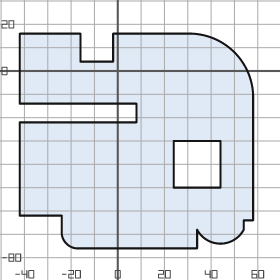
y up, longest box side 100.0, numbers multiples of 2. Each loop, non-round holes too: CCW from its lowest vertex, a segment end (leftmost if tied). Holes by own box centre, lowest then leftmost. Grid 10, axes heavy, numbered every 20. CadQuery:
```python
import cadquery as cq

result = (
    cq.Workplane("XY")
    .moveTo(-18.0, -76.0)
    .lineTo(34.0, -76.0)
    .lineTo(34.0, -68.0)
    .threePointArc((44.0, -74.0), (54.0, -68.0))
    .lineTo(54.0, -64.0)
    .lineTo(58.0, -64.0)
    .lineTo(58.0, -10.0)
    .threePointArc((50.0, 8.0), (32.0, 16.0))
    .lineTo(-2.0, 16.0)
    .lineTo(-2.0, 4.0)
    .lineTo(-16.0, 4.0)
    .lineTo(-16.0, 16.0)
    .lineTo(-42.0, 16.0)
    .lineTo(-42.0, -14.0)
    .lineTo(8.0, -14.0)
    .lineTo(8.0, -22.0)
    .lineTo(-42.0, -22.0)
    .lineTo(-42.0, -62.0)
    .lineTo(-24.0, -62.0)
    .lineTo(-24.0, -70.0)
    .threePointArc((-22.0, -74.0), (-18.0, -76.0))
    .close()
    .moveTo(24.0, -50.0)
    .lineTo(44.0, -50.0)
    .lineTo(44.0, -30.0)
    .lineTo(24.0, -30.0)
    .close()
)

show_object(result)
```